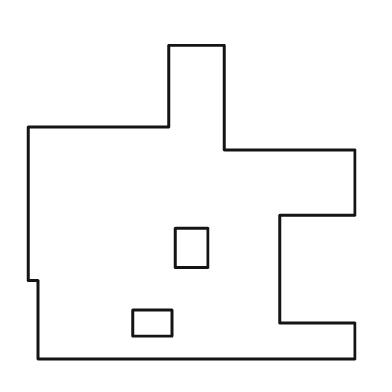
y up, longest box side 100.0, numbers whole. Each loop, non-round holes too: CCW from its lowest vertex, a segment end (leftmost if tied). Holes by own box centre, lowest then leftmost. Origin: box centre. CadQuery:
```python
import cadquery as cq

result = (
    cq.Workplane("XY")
    .moveTo(-47.0, -48.0)
    .lineTo(50.0, -48.0)
    .lineTo(50.0, -37.0)
    .lineTo(27.0, -37.0)
    .lineTo(27.0, -4.0)
    .lineTo(50.0, -4.0)
    .lineTo(50.0, 16.0)
    .lineTo(10.0, 16.0)
    .lineTo(10.0, 48.0)
    .lineTo(-7.0, 48.0)
    .lineTo(-7.0, 23.0)
    .lineTo(-50.0, 23.0)
    .lineTo(-50.0, -24.0)
    .lineTo(-47.0, -24.0)
    .close()
    .moveTo(-18.0, -41.0)
    .lineTo(-6.0, -41.0)
    .lineTo(-6.0, -33.0)
    .lineTo(-18.0, -33.0)
    .close()
    .moveTo(-5.0, -20.0)
    .lineTo(5.0, -20.0)
    .lineTo(5.0, -8.0)
    .lineTo(-5.0, -8.0)
    .close()
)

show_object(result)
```